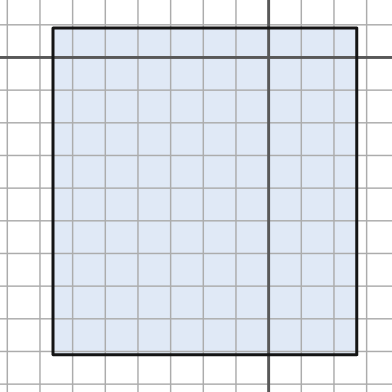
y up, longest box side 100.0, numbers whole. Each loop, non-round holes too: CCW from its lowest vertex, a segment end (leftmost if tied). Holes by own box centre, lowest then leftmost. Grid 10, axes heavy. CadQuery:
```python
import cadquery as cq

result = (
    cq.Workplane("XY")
    .moveTo(-66.0, -91.0)
    .lineTo(27.0, -91.0)
    .lineTo(27.0, 9.0)
    .lineTo(-66.0, 9.0)
    .close()
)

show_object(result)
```